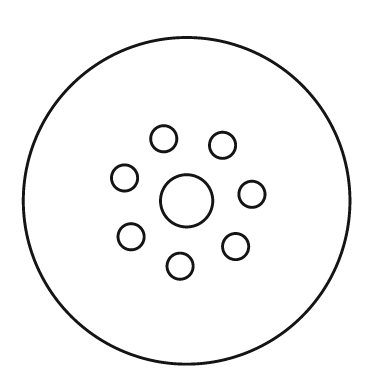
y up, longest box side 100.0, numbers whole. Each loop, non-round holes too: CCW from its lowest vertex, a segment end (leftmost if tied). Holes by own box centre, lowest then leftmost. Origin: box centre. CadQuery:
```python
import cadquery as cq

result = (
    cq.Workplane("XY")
    .moveTo(0.0, 0.0)
    .circle(50.0)
    .moveTo(-2.0, -20.0)
    .circle(4.0)
    .moveTo(15.0, -14.0)
    .circle(4.0)
    .moveTo(-17.0, -11.0)
    .circle(4.0)
    .moveTo(0.0, 0.0)
    .circle(8.0)
    .moveTo(20.0, 2.0)
    .circle(4.0)
    .moveTo(-19.0, 7.0)
    .circle(4.0)
    .moveTo(11.0, 17.0)
    .circle(4.0)
    .moveTo(-7.0, 19.0)
    .circle(4.0)
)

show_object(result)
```